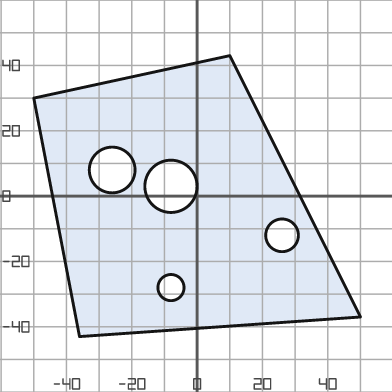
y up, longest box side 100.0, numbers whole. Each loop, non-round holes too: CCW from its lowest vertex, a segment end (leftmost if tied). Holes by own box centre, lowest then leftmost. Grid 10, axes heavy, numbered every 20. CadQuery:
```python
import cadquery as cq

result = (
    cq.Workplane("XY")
    .moveTo(-36.0, -43.0)
    .lineTo(50.0, -37.0)
    .lineTo(10.0, 43.0)
    .lineTo(-50.0, 30.0)
    .close()
    .moveTo(-8.0, -28.0)
    .circle(4.0)
    .moveTo(26.0, -12.0)
    .circle(5.0)
    .moveTo(-8.0, 3.0)
    .circle(8.0)
    .moveTo(-26.0, 8.0)
    .circle(7.0)
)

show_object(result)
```